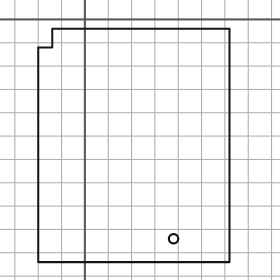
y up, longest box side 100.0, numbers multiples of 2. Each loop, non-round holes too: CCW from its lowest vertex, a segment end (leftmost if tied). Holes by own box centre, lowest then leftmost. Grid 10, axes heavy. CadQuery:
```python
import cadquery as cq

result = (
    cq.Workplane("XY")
    .moveTo(-20.0, -104.0)
    .lineTo(62.0, -104.0)
    .lineTo(62.0, -4.0)
    .lineTo(-14.0, -4.0)
    .lineTo(-14.0, -12.0)
    .lineTo(-20.0, -12.0)
    .close()
    .moveTo(38.0, -94.0)
    .circle(2.0)
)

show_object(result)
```